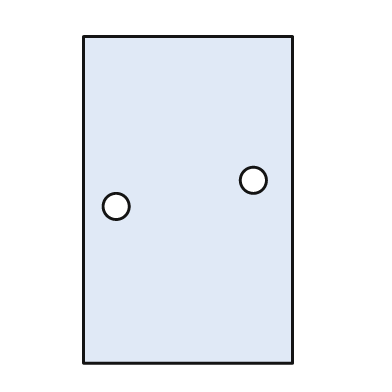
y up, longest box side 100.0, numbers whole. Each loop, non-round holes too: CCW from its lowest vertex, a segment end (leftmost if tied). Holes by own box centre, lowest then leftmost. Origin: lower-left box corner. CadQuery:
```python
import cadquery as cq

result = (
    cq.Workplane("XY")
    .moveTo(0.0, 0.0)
    .lineTo(64.0, 0.0)
    .lineTo(64.0, 100.0)
    .lineTo(0.0, 100.0)
    .close()
    .moveTo(10.0, 48.0)
    .circle(4.0)
    .moveTo(52.0, 56.0)
    .circle(4.0)
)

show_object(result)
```